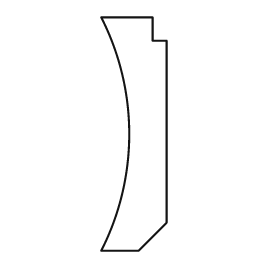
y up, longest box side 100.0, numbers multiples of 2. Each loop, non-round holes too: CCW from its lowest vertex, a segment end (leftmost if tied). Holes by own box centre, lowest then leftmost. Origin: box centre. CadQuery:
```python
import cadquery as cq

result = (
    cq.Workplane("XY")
    .moveTo(-14.0, -50.0)
    .lineTo(2.0, -50.0)
    .lineTo(14.0, -38.0)
    .lineTo(14.0, 40.0)
    .lineTo(8.0, 40.0)
    .lineTo(8.0, 50.0)
    .lineTo(-14.0, 50.0)
    .threePointArc((-2.0, 0.0), (-14.0, -50.0))
    .close()
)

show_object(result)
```